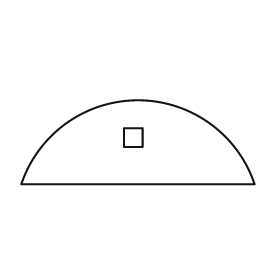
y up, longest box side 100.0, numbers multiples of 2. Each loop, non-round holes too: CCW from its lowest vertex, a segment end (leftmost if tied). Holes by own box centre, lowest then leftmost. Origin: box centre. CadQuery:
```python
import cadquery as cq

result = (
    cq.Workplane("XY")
    .moveTo(-50.0, -18.0)
    .lineTo(50.0, -18.0)
    .threePointArc((0.0, 18.0), (-50.0, -18.0))
    .close()
    .moveTo(-6.0, -2.0)
    .lineTo(2.0, -2.0)
    .lineTo(2.0, 6.0)
    .lineTo(-6.0, 6.0)
    .close()
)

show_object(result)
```